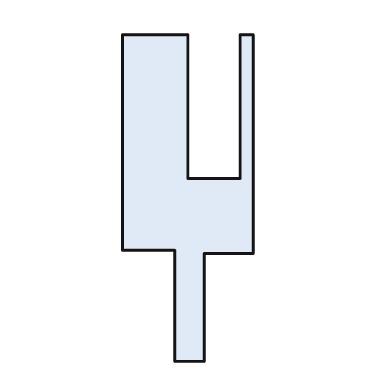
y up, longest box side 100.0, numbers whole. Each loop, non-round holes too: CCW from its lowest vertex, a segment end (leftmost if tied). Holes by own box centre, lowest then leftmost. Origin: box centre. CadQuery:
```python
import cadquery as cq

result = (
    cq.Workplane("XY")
    .moveTo(-4.0, -50.0)
    .lineTo(5.0, -50.0)
    .lineTo(5.0, -17.0)
    .lineTo(20.0, -17.0)
    .lineTo(20.0, 50.0)
    .lineTo(16.0, 50.0)
    .lineTo(16.0, 6.0)
    .lineTo(0.0, 6.0)
    .lineTo(0.0, 50.0)
    .lineTo(-20.0, 50.0)
    .lineTo(-20.0, -16.0)
    .lineTo(-4.0, -16.0)
    .close()
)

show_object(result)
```